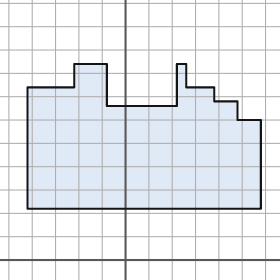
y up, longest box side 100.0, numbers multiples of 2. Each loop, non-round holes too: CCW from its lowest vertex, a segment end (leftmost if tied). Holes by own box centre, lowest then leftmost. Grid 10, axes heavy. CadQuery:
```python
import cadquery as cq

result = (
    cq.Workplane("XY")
    .moveTo(-42.0, 22.0)
    .lineTo(58.0, 22.0)
    .lineTo(58.0, 60.0)
    .lineTo(48.0, 60.0)
    .lineTo(48.0, 68.0)
    .lineTo(38.0, 68.0)
    .lineTo(38.0, 74.0)
    .lineTo(26.0, 74.0)
    .lineTo(26.0, 84.0)
    .lineTo(22.0, 84.0)
    .lineTo(22.0, 66.0)
    .lineTo(-8.0, 66.0)
    .lineTo(-8.0, 84.0)
    .lineTo(-22.0, 84.0)
    .lineTo(-22.0, 74.0)
    .lineTo(-42.0, 74.0)
    .close()
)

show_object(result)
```